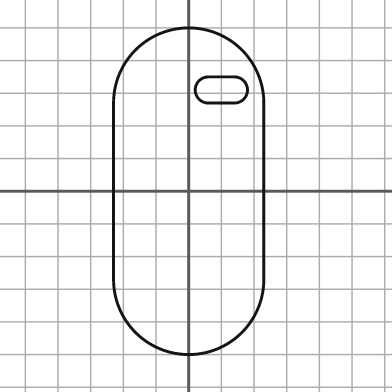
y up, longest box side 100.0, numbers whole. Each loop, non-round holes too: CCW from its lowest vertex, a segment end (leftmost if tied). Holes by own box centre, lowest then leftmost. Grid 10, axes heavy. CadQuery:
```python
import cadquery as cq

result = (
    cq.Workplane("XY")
    .moveTo(-23.0, -27.0)
    .threePointArc((0.0, -50.0), (23.0, -27.0))
    .lineTo(23.0, 27.0)
    .threePointArc((0.0, 50.0), (-23.0, 27.0))
    .close()
    .moveTo(6.0, 27.0)
    .lineTo(14.0, 27.0)
    .threePointArc((18.0, 31.0), (14.0, 35.0))
    .lineTo(6.0, 35.0)
    .threePointArc((2.0, 31.0), (6.0, 27.0))
    .close()
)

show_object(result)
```